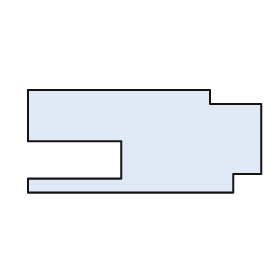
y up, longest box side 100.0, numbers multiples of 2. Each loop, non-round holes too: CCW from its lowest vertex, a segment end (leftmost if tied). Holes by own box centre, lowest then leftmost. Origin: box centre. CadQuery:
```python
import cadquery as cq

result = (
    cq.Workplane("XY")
    .moveTo(-50.0, -22.0)
    .lineTo(38.0, -22.0)
    .lineTo(38.0, -14.0)
    .lineTo(50.0, -14.0)
    .lineTo(50.0, 16.0)
    .lineTo(28.0, 16.0)
    .lineTo(28.0, 22.0)
    .lineTo(-50.0, 22.0)
    .lineTo(-50.0, 0.0)
    .lineTo(-10.0, 0.0)
    .lineTo(-10.0, -16.0)
    .lineTo(-50.0, -16.0)
    .close()
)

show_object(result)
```